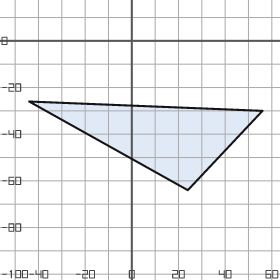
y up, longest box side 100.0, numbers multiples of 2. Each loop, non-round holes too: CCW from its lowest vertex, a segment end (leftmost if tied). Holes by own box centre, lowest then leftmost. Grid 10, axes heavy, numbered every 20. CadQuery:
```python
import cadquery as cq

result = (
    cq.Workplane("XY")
    .moveTo(24.0, -64.0)
    .lineTo(56.0, -30.0)
    .lineTo(-44.0, -26.0)
    .close()
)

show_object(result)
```